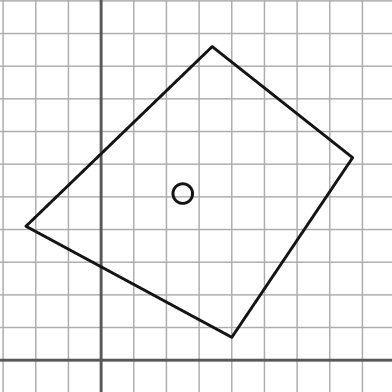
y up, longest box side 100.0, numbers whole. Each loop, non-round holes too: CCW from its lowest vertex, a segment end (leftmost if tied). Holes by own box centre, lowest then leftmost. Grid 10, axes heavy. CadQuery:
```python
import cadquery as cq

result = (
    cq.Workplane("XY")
    .moveTo(40.0, 7.0)
    .lineTo(77.0, 62.0)
    .lineTo(34.0, 96.0)
    .lineTo(-23.0, 41.0)
    .close()
    .moveTo(25.0, 51.0)
    .circle(3.0)
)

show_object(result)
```